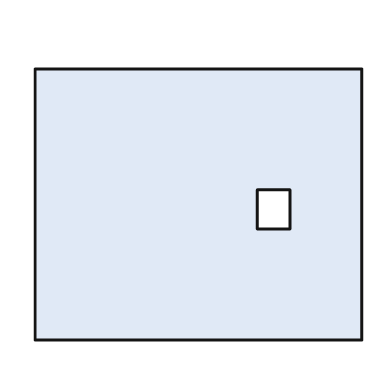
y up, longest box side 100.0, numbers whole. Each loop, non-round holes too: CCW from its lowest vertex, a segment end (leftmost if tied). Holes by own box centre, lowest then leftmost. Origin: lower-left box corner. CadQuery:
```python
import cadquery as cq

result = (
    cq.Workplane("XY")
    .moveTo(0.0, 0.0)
    .lineTo(100.0, 0.0)
    .lineTo(100.0, 83.0)
    .lineTo(0.0, 83.0)
    .close()
    .moveTo(68.0, 34.0)
    .lineTo(78.0, 34.0)
    .lineTo(78.0, 46.0)
    .lineTo(68.0, 46.0)
    .close()
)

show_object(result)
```